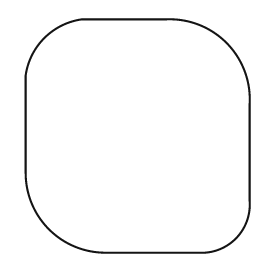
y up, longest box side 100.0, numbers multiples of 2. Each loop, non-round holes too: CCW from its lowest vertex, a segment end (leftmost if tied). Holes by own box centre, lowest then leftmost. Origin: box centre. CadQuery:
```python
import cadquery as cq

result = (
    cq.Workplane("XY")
    .moveTo(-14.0, -50.0)
    .lineTo(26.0, -50.0)
    .threePointArc((42.0, -44.0), (48.0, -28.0))
    .lineTo(48.0, 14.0)
    .threePointArc((38.0, 40.0), (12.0, 50.0))
    .lineTo(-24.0, 50.0)
    .threePointArc((-40.0, 42.0), (-48.0, 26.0))
    .lineTo(-48.0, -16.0)
    .threePointArc((-38.0, -40.0), (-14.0, -50.0))
    .close()
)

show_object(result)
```